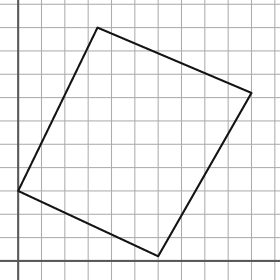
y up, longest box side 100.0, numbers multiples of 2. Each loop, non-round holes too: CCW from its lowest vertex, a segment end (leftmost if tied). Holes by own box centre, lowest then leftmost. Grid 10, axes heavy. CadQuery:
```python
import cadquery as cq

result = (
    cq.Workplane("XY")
    .moveTo(60.0, 2.0)
    .lineTo(100.0, 72.0)
    .lineTo(34.0, 100.0)
    .lineTo(0.0, 30.0)
    .close()
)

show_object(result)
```